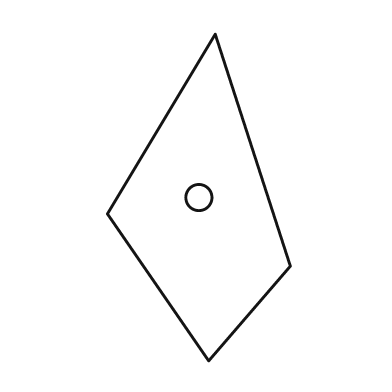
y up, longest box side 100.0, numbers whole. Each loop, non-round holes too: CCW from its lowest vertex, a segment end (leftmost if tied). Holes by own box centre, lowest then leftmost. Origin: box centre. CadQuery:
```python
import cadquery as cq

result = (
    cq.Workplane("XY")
    .moveTo(3.0, -50.0)
    .lineTo(28.0, -21.0)
    .lineTo(5.0, 50.0)
    .lineTo(-28.0, -5.0)
    .close()
    .moveTo(0.0, 0.0)
    .circle(4.0)
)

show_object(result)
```